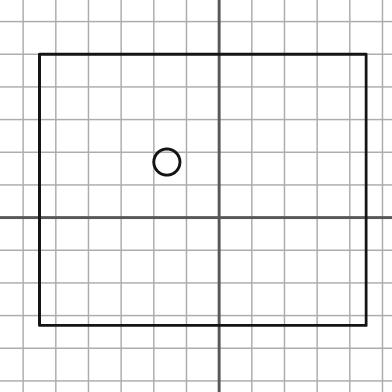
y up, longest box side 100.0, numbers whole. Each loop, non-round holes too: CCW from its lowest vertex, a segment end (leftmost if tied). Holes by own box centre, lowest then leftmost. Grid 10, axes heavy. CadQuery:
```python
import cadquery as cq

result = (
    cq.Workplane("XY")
    .moveTo(-55.0, -33.0)
    .lineTo(45.0, -33.0)
    .lineTo(45.0, 50.0)
    .lineTo(-55.0, 50.0)
    .close()
    .moveTo(-16.0, 17.0)
    .circle(4.0)
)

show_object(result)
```